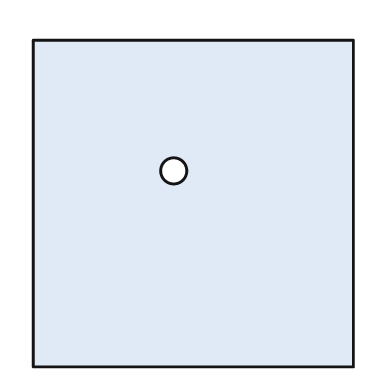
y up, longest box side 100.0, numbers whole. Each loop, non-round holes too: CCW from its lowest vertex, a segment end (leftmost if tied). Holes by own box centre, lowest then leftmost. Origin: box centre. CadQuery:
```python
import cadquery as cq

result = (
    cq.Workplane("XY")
    .moveTo(-49.0, -50.0)
    .lineTo(49.0, -50.0)
    .lineTo(49.0, 50.0)
    .lineTo(-49.0, 50.0)
    .close()
    .moveTo(-6.0, 10.0)
    .circle(4.0)
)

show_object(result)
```